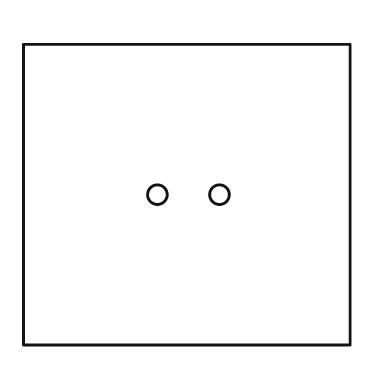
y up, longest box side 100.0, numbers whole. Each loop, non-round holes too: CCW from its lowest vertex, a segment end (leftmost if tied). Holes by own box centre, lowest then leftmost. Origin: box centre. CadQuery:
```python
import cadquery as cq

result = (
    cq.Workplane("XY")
    .moveTo(-50.0, -46.0)
    .lineTo(50.0, -46.0)
    .lineTo(50.0, 46.0)
    .lineTo(-50.0, 46.0)
    .close()
    .moveTo(-9.0, 0.0)
    .circle(3.0)
    .moveTo(10.0, 0.0)
    .circle(3.0)
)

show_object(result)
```